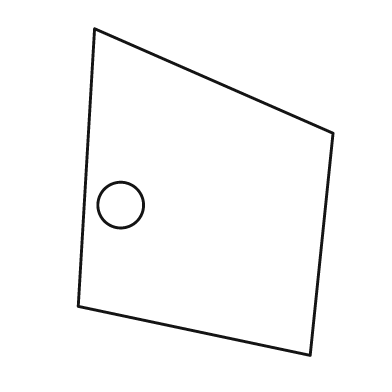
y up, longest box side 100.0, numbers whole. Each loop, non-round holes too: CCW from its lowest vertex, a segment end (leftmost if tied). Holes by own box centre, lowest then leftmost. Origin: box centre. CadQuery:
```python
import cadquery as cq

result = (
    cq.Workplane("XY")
    .moveTo(32.0, -50.0)
    .lineTo(39.0, 18.0)
    .lineTo(-34.0, 50.0)
    .lineTo(-39.0, -35.0)
    .close()
    .moveTo(-26.0, -4.0)
    .circle(7.0)
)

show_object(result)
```